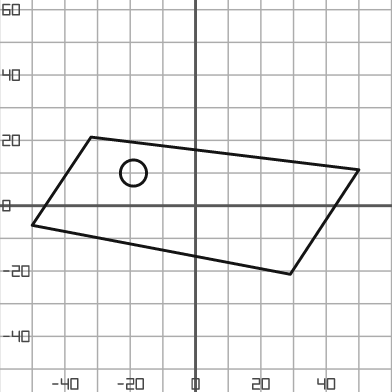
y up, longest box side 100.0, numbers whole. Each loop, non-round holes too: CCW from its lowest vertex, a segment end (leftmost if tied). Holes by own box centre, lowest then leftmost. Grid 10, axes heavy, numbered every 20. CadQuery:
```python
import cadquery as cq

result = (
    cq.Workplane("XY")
    .moveTo(29.0, -21.0)
    .lineTo(50.0, 11.0)
    .lineTo(-32.0, 21.0)
    .lineTo(-50.0, -6.0)
    .close()
    .moveTo(-19.0, 10.0)
    .circle(4.0)
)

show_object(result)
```